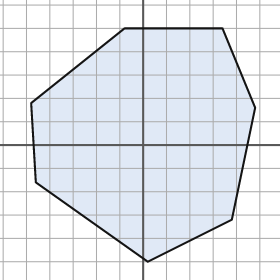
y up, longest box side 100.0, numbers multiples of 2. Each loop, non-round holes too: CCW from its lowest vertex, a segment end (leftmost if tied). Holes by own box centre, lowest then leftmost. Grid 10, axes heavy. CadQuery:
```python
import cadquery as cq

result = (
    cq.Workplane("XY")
    .moveTo(2.0, -50.0)
    .lineTo(38.0, -32.0)
    .lineTo(48.0, 16.0)
    .lineTo(34.0, 50.0)
    .lineTo(-8.0, 50.0)
    .lineTo(-48.0, 18.0)
    .lineTo(-46.0, -16.0)
    .close()
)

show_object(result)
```